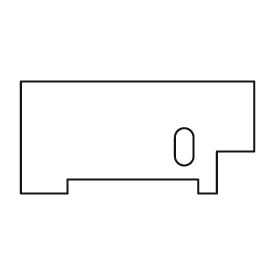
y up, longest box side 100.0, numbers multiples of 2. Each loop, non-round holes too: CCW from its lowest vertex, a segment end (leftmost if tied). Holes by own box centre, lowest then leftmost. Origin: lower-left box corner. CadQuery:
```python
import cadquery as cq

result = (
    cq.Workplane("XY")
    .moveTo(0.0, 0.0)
    .lineTo(20.0, 0.0)
    .lineTo(20.0, 6.0)
    .lineTo(76.0, 6.0)
    .lineTo(76.0, 0.0)
    .lineTo(84.0, 0.0)
    .lineTo(84.0, 18.0)
    .lineTo(100.0, 18.0)
    .lineTo(100.0, 48.0)
    .lineTo(0.0, 48.0)
    .close()
    .moveTo(66.0, 16.0)
    .threePointArc((70.0, 12.0), (74.0, 16.0))
    .lineTo(74.0, 24.0)
    .threePointArc((70.0, 28.0), (66.0, 24.0))
    .close()
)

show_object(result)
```